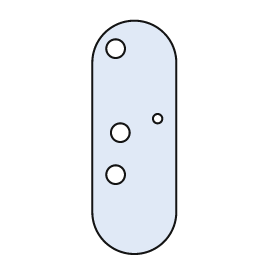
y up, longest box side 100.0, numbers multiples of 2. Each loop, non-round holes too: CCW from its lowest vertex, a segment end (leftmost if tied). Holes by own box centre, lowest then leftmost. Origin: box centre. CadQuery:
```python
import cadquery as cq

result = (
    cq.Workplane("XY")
    .moveTo(-18.0, -32.0)
    .threePointArc((0.0, -50.0), (18.0, -32.0))
    .lineTo(18.0, 32.0)
    .threePointArc((0.0, 50.0), (-18.0, 32.0))
    .close()
    .moveTo(-8.0, -16.0)
    .circle(4.0)
    .moveTo(-6.0, 2.0)
    .circle(4.0)
    .moveTo(10.0, 8.0)
    .circle(2.0)
    .moveTo(-8.0, 38.0)
    .circle(4.0)
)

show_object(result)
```